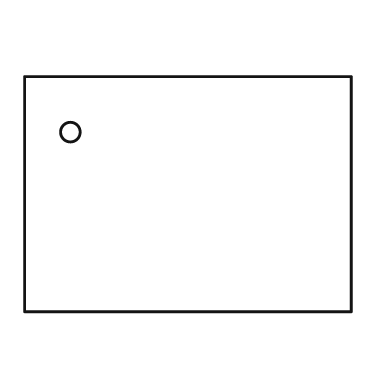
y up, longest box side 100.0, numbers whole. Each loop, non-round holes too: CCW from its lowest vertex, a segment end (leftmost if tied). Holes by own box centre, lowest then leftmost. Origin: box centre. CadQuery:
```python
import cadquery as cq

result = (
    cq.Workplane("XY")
    .moveTo(-50.0, -36.0)
    .lineTo(50.0, -36.0)
    .lineTo(50.0, 36.0)
    .lineTo(-50.0, 36.0)
    .close()
    .moveTo(-36.0, 19.0)
    .circle(3.0)
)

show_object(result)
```